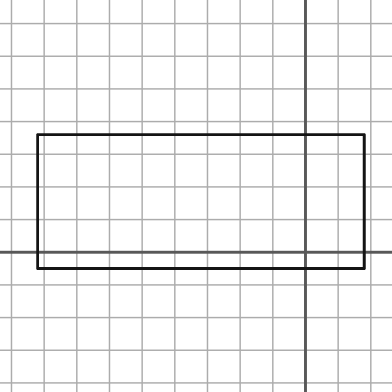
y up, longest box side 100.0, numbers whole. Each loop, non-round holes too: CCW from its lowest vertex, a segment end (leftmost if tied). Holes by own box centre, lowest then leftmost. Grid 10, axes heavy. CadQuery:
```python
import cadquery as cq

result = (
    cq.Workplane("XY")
    .moveTo(-82.0, -5.0)
    .lineTo(18.0, -5.0)
    .lineTo(18.0, 36.0)
    .lineTo(-82.0, 36.0)
    .close()
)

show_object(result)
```